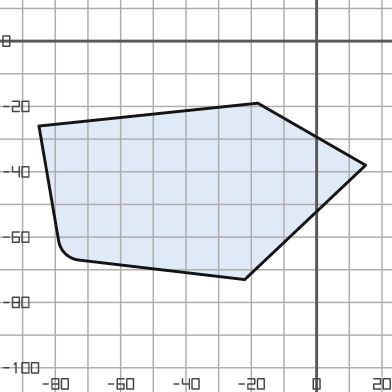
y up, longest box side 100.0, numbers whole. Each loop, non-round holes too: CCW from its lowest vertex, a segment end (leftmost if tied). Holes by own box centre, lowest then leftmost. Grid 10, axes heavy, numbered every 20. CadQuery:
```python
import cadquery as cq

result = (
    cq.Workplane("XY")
    .moveTo(-22.0, -73.0)
    .lineTo(15.0, -38.0)
    .lineTo(-18.0, -19.0)
    .lineTo(-85.0, -26.0)
    .lineTo(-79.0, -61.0)
    .threePointArc((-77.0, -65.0), (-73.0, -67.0))
    .close()
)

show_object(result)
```